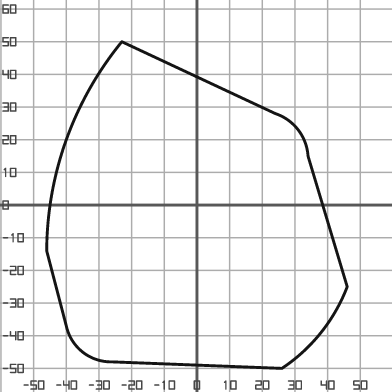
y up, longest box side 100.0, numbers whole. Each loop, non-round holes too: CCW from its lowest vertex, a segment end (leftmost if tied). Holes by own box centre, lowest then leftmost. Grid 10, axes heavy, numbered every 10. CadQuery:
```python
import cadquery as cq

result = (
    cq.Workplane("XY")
    .moveTo(26.0, -50.0)
    .threePointArc((38.0, -39.0), (46.0, -25.0))
    .lineTo(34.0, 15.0)
    .threePointArc((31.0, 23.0), (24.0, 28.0))
    .lineTo(-23.0, 50.0)
    .threePointArc((-40.0, 20.0), (-46.0, -14.0))
    .lineTo(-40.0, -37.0)
    .threePointArc((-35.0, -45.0), (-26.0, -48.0))
    .close()
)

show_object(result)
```